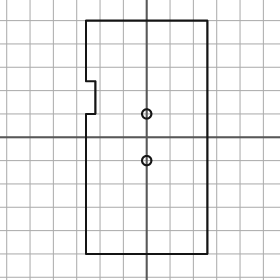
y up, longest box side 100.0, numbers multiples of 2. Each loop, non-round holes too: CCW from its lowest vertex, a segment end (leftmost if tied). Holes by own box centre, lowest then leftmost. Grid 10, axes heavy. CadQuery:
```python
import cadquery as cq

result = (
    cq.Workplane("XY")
    .moveTo(-26.0, -50.0)
    .lineTo(26.0, -50.0)
    .lineTo(26.0, 50.0)
    .lineTo(-26.0, 50.0)
    .lineTo(-26.0, 24.0)
    .lineTo(-22.0, 24.0)
    .lineTo(-22.0, 10.0)
    .lineTo(-26.0, 10.0)
    .close()
    .moveTo(0.0, -10.0)
    .circle(2.0)
    .moveTo(0.0, 10.0)
    .circle(2.0)
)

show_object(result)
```